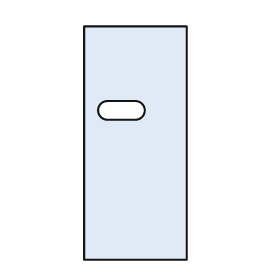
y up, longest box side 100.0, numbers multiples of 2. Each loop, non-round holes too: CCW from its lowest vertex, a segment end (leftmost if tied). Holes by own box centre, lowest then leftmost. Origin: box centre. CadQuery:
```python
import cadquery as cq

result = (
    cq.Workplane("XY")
    .moveTo(-22.0, -50.0)
    .lineTo(22.0, -50.0)
    .lineTo(22.0, 50.0)
    .lineTo(-22.0, 50.0)
    .close()
    .moveTo(-12.0, 10.0)
    .lineTo(0.0, 10.0)
    .threePointArc((4.0, 14.0), (0.0, 18.0))
    .lineTo(-12.0, 18.0)
    .threePointArc((-16.0, 14.0), (-12.0, 10.0))
    .close()
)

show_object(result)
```